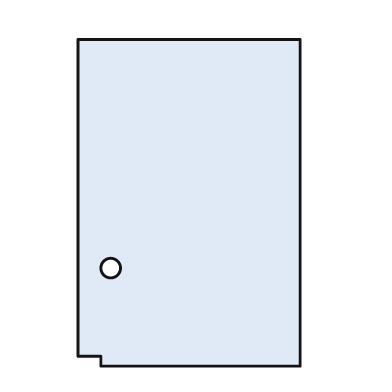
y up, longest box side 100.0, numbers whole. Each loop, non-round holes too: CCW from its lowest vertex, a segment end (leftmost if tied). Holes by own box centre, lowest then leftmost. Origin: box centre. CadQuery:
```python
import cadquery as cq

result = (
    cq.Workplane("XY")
    .moveTo(-27.0, -50.0)
    .lineTo(34.0, -50.0)
    .lineTo(34.0, 50.0)
    .lineTo(-34.0, 50.0)
    .lineTo(-34.0, -47.0)
    .lineTo(-27.0, -47.0)
    .close()
    .moveTo(-24.0, -20.0)
    .circle(3.0)
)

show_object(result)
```